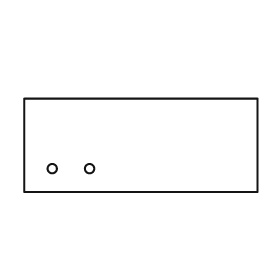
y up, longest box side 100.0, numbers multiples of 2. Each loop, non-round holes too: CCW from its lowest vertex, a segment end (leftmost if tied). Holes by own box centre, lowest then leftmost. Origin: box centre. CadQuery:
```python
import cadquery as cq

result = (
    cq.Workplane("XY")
    .moveTo(-50.0, -20.0)
    .lineTo(50.0, -20.0)
    .lineTo(50.0, 20.0)
    .lineTo(-50.0, 20.0)
    .close()
    .moveTo(-38.0, -10.0)
    .circle(2.0)
    .moveTo(-22.0, -10.0)
    .circle(2.0)
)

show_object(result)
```